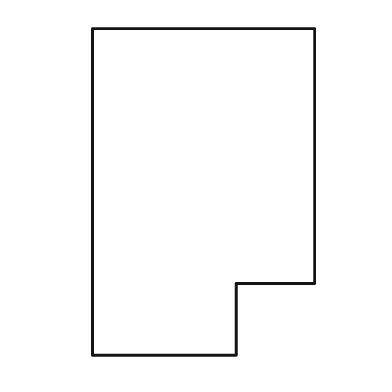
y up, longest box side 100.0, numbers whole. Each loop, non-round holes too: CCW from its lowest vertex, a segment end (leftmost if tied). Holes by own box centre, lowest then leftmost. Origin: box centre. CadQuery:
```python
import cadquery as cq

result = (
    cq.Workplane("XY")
    .moveTo(-34.0, -50.0)
    .lineTo(10.0, -50.0)
    .lineTo(10.0, -28.0)
    .lineTo(34.0, -28.0)
    .lineTo(34.0, 50.0)
    .lineTo(-34.0, 50.0)
    .close()
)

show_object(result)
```